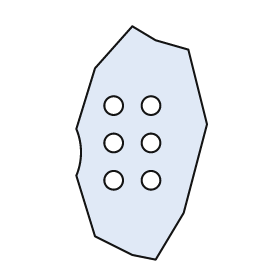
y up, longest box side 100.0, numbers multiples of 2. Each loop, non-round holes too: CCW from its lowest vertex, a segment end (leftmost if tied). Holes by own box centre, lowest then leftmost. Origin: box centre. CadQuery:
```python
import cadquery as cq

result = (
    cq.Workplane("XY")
    .moveTo(6.0, -50.0)
    .lineTo(18.0, -30.0)
    .lineTo(28.0, 8.0)
    .lineTo(20.0, 40.0)
    .lineTo(6.0, 44.0)
    .lineTo(-4.0, 50.0)
    .lineTo(-20.0, 32.0)
    .lineTo(-28.0, 6.0)
    .threePointArc((-26.0, -4.0), (-28.0, -14.0))
    .lineTo(-20.0, -40.0)
    .lineTo(-4.0, -48.0)
    .close()
    .moveTo(-12.0, -16.0)
    .circle(4.0)
    .moveTo(4.0, -16.0)
    .circle(4.0)
    .moveTo(-12.0, 0.0)
    .circle(4.0)
    .moveTo(4.0, 0.0)
    .circle(4.0)
    .moveTo(-12.0, 16.0)
    .circle(4.0)
    .moveTo(4.0, 16.0)
    .circle(4.0)
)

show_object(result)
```